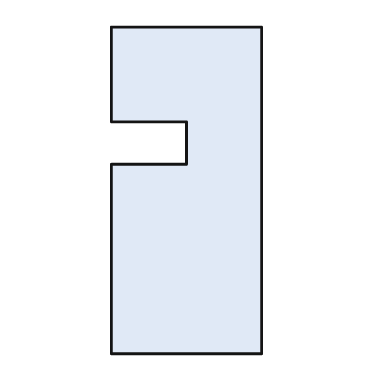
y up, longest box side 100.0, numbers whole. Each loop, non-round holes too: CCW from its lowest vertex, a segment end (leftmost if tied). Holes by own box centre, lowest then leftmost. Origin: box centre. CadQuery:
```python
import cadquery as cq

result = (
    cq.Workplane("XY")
    .moveTo(-23.0, -50.0)
    .lineTo(23.0, -50.0)
    .lineTo(23.0, 50.0)
    .lineTo(-23.0, 50.0)
    .lineTo(-23.0, 21.0)
    .lineTo(0.0, 21.0)
    .lineTo(0.0, 8.0)
    .lineTo(-23.0, 8.0)
    .close()
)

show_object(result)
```